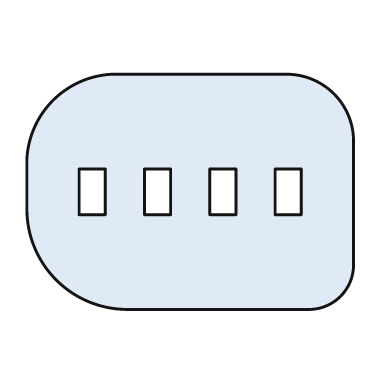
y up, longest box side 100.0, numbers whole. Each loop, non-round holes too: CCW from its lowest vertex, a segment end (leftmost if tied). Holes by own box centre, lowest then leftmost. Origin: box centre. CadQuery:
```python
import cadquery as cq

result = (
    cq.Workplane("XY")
    .moveTo(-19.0, -36.0)
    .lineTo(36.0, -36.0)
    .threePointArc((46.0, -32.0), (50.0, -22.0))
    .lineTo(50.0, 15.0)
    .threePointArc((44.0, 30.0), (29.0, 36.0))
    .lineTo(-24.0, 36.0)
    .threePointArc((-42.0, 28.0), (-50.0, 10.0))
    .lineTo(-50.0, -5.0)
    .threePointArc((-41.0, -27.0), (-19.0, -36.0))
    .close()
    .moveTo(-34.0, -7.0)
    .lineTo(-26.0, -7.0)
    .lineTo(-26.0, 7.0)
    .lineTo(-34.0, 7.0)
    .close()
    .moveTo(-14.0, -7.0)
    .lineTo(-6.0, -7.0)
    .lineTo(-6.0, 7.0)
    .lineTo(-14.0, 7.0)
    .close()
    .moveTo(6.0, -7.0)
    .lineTo(14.0, -7.0)
    .lineTo(14.0, 7.0)
    .lineTo(6.0, 7.0)
    .close()
    .moveTo(26.0, -7.0)
    .lineTo(34.0, -7.0)
    .lineTo(34.0, 7.0)
    .lineTo(26.0, 7.0)
    .close()
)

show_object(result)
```